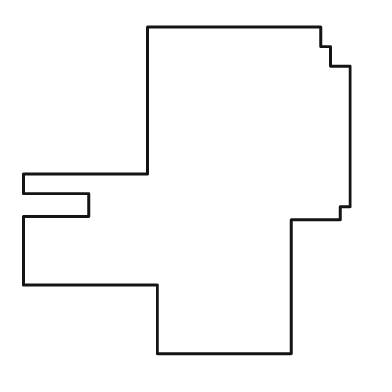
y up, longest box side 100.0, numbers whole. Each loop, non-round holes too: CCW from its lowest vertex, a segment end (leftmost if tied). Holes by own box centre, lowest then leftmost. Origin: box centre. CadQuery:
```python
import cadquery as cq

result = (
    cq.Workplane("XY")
    .moveTo(-9.0, -50.0)
    .lineTo(32.0, -50.0)
    .lineTo(32.0, -9.0)
    .lineTo(47.0, -9.0)
    .lineTo(47.0, -5.0)
    .lineTo(50.0, -5.0)
    .lineTo(50.0, 38.0)
    .lineTo(44.0, 38.0)
    .lineTo(44.0, 44.0)
    .lineTo(41.0, 44.0)
    .lineTo(41.0, 50.0)
    .lineTo(-12.0, 50.0)
    .lineTo(-12.0, 5.0)
    .lineTo(-50.0, 5.0)
    .lineTo(-50.0, -1.0)
    .lineTo(-30.0, -1.0)
    .lineTo(-30.0, -8.0)
    .lineTo(-50.0, -8.0)
    .lineTo(-50.0, -29.0)
    .lineTo(-9.0, -29.0)
    .close()
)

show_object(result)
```